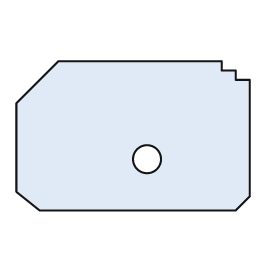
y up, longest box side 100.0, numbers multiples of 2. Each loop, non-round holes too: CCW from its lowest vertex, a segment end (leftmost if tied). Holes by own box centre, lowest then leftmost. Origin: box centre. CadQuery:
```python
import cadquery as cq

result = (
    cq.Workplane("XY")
    .moveTo(-40.0, -32.0)
    .lineTo(44.0, -32.0)
    .lineTo(50.0, -26.0)
    .lineTo(50.0, 24.0)
    .lineTo(44.0, 24.0)
    .lineTo(44.0, 28.0)
    .lineTo(38.0, 28.0)
    .lineTo(38.0, 32.0)
    .lineTo(-32.0, 32.0)
    .lineTo(-50.0, 14.0)
    .lineTo(-50.0, -24.0)
    .close()
    .moveTo(6.0, -10.0)
    .circle(6.0)
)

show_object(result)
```